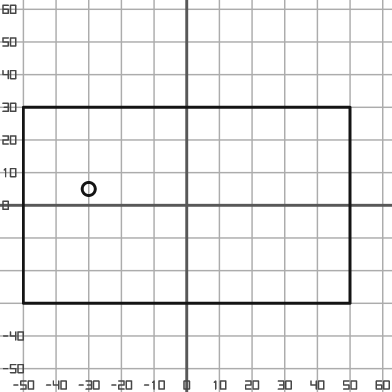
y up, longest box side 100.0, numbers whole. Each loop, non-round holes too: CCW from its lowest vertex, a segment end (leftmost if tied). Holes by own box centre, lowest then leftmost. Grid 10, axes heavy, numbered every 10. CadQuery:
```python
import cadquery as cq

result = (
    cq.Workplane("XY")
    .moveTo(-50.0, -30.0)
    .lineTo(50.0, -30.0)
    .lineTo(50.0, 30.0)
    .lineTo(-50.0, 30.0)
    .close()
    .moveTo(-30.0, 5.0)
    .circle(2.0)
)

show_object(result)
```